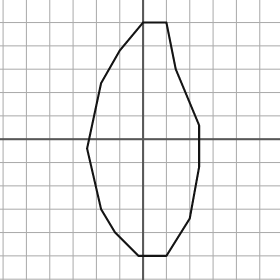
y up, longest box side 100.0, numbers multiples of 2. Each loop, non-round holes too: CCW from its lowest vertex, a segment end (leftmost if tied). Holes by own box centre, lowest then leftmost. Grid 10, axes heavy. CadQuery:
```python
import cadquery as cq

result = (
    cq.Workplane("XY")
    .moveTo(-2.0, -50.0)
    .lineTo(10.0, -50.0)
    .lineTo(20.0, -34.0)
    .lineTo(24.0, -12.0)
    .lineTo(24.0, 6.0)
    .lineTo(14.0, 30.0)
    .lineTo(10.0, 50.0)
    .lineTo(0.0, 50.0)
    .lineTo(-10.0, 38.0)
    .lineTo(-18.0, 24.0)
    .lineTo(-24.0, -4.0)
    .lineTo(-18.0, -30.0)
    .lineTo(-12.0, -40.0)
    .close()
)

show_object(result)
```